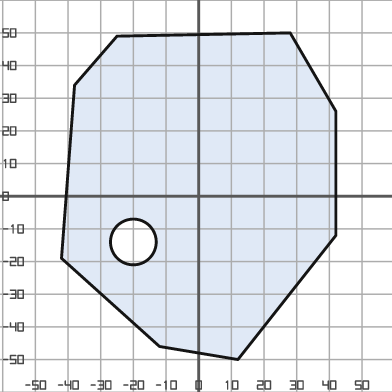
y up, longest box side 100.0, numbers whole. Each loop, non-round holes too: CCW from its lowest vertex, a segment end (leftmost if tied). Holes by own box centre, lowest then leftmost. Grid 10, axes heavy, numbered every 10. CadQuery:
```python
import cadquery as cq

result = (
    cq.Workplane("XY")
    .moveTo(12.0, -50.0)
    .lineTo(42.0, -12.0)
    .lineTo(42.0, 26.0)
    .lineTo(28.0, 50.0)
    .lineTo(-25.0, 49.0)
    .lineTo(-38.0, 34.0)
    .lineTo(-42.0, -19.0)
    .lineTo(-12.0, -46.0)
    .close()
    .moveTo(-20.0, -14.0)
    .circle(7.0)
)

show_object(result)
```